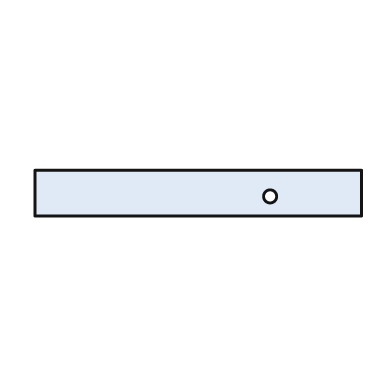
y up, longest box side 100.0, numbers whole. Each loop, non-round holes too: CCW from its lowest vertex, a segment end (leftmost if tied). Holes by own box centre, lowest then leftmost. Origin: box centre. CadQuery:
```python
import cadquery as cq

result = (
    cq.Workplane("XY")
    .moveTo(-50.0, -7.0)
    .lineTo(50.0, -7.0)
    .lineTo(50.0, 7.0)
    .lineTo(-50.0, 7.0)
    .close()
    .moveTo(22.0, -1.0)
    .circle(2.0)
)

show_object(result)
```